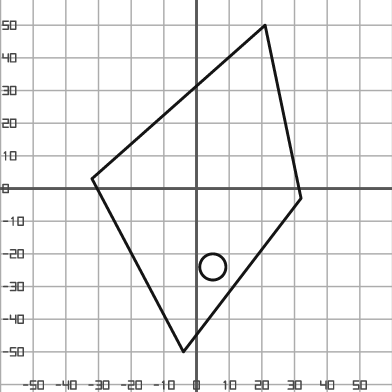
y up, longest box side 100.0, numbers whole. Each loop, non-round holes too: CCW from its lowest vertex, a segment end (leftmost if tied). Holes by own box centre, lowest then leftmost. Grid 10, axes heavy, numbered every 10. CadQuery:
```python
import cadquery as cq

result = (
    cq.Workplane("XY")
    .moveTo(-4.0, -50.0)
    .lineTo(32.0, -3.0)
    .lineTo(21.0, 50.0)
    .lineTo(-32.0, 3.0)
    .close()
    .moveTo(5.0, -24.0)
    .circle(4.0)
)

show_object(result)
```